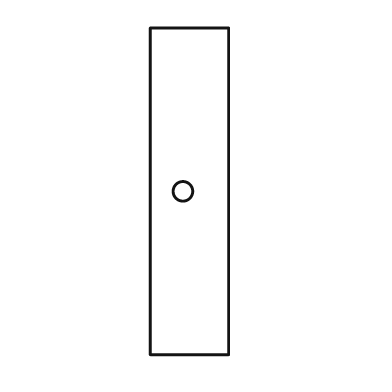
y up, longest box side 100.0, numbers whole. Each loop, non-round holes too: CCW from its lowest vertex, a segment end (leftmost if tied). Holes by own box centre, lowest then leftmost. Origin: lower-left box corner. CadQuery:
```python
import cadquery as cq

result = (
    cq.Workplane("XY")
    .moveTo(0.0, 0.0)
    .lineTo(24.0, 0.0)
    .lineTo(24.0, 100.0)
    .lineTo(0.0, 100.0)
    .close()
    .moveTo(10.0, 50.0)
    .circle(3.0)
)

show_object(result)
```